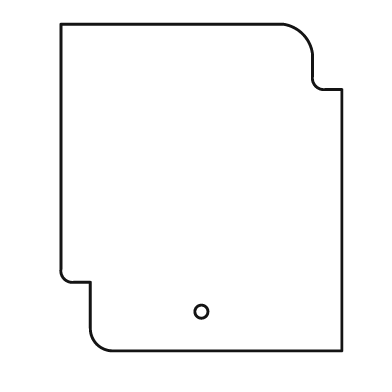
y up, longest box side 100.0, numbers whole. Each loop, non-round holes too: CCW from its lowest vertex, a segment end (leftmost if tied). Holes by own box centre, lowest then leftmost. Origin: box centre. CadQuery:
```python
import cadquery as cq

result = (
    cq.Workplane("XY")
    .moveTo(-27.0, -50.0)
    .lineTo(43.0, -50.0)
    .lineTo(43.0, 30.0)
    .lineTo(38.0, 30.0)
    .threePointArc((35.0, 31.0), (34.0, 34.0))
    .lineTo(34.0, 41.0)
    .threePointArc((31.0, 47.0), (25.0, 50.0))
    .lineTo(-43.0, 50.0)
    .lineTo(-43.0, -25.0)
    .threePointArc((-42.0, -28.0), (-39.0, -29.0))
    .lineTo(-34.0, -29.0)
    .lineTo(-34.0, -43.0)
    .threePointArc((-32.0, -48.0), (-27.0, -50.0))
    .close()
    .moveTo(0.0, -38.0)
    .circle(2.0)
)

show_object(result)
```